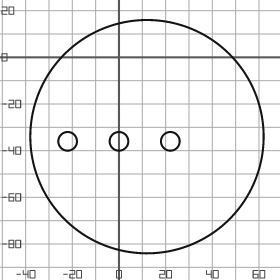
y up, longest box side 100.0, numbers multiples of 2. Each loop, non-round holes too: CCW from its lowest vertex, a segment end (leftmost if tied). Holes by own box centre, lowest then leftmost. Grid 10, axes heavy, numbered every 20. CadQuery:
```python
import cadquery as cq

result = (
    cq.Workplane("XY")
    .moveTo(12.0, -34.0)
    .circle(50.0)
    .moveTo(-22.0, -36.0)
    .circle(4.0)
    .moveTo(0.0, -36.0)
    .circle(4.0)
    .moveTo(22.0, -36.0)
    .circle(4.0)
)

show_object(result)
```